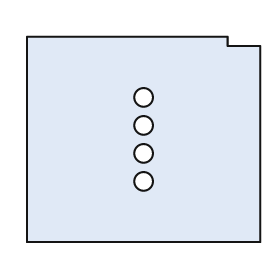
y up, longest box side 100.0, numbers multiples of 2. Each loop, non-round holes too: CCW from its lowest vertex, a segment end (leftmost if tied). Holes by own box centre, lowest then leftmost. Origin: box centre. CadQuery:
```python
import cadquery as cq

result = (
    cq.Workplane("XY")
    .moveTo(-50.0, -44.0)
    .lineTo(50.0, -44.0)
    .lineTo(50.0, 40.0)
    .lineTo(36.0, 40.0)
    .lineTo(36.0, 44.0)
    .lineTo(-50.0, 44.0)
    .close()
    .moveTo(0.0, -18.0)
    .circle(4.0)
    .moveTo(0.0, -6.0)
    .circle(4.0)
    .moveTo(0.0, 6.0)
    .circle(4.0)
    .moveTo(0.0, 18.0)
    .circle(4.0)
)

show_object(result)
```